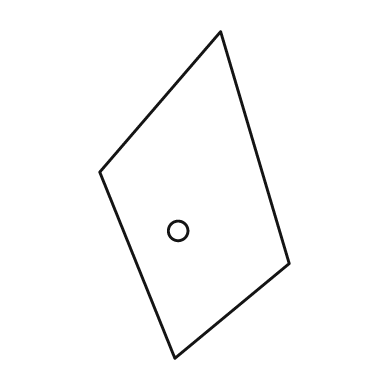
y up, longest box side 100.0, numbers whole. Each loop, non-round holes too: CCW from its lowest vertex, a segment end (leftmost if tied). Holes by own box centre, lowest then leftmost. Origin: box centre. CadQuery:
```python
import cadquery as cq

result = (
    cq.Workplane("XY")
    .moveTo(-6.0, -50.0)
    .lineTo(29.0, -21.0)
    .lineTo(8.0, 50.0)
    .lineTo(-29.0, 7.0)
    .close()
    .moveTo(-5.0, -11.0)
    .circle(3.0)
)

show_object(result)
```